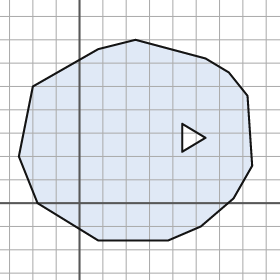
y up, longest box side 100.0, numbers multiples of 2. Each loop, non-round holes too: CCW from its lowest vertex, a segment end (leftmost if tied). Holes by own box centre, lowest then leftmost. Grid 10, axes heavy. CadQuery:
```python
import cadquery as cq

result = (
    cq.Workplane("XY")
    .moveTo(8.0, -16.0)
    .lineTo(38.0, -16.0)
    .lineTo(52.0, -10.0)
    .lineTo(66.0, 2.0)
    .lineTo(74.0, 16.0)
    .lineTo(72.0, 46.0)
    .lineTo(64.0, 56.0)
    .lineTo(54.0, 62.0)
    .lineTo(24.0, 70.0)
    .lineTo(8.0, 66.0)
    .lineTo(-20.0, 50.0)
    .lineTo(-26.0, 20.0)
    .lineTo(-18.0, 0.0)
    .close()
    .moveTo(44.0, 22.0)
    .lineTo(54.0, 28.0)
    .lineTo(44.0, 34.0)
    .close()
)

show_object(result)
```